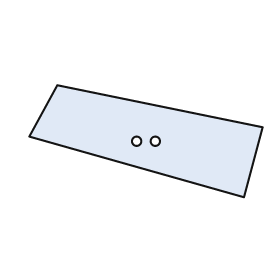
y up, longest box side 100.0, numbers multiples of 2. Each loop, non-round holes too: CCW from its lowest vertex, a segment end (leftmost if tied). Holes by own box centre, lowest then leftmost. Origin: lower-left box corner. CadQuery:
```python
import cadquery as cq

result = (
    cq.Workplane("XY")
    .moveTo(92.0, 0.0)
    .lineTo(100.0, 30.0)
    .lineTo(12.0, 48.0)
    .lineTo(0.0, 26.0)
    .close()
    .moveTo(46.0, 24.0)
    .circle(2.0)
    .moveTo(54.0, 24.0)
    .circle(2.0)
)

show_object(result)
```